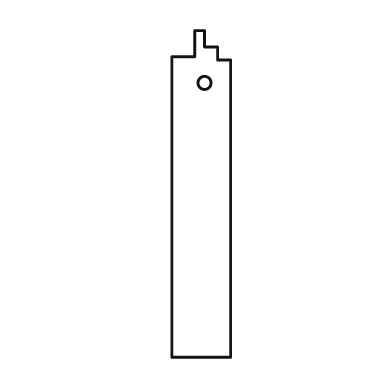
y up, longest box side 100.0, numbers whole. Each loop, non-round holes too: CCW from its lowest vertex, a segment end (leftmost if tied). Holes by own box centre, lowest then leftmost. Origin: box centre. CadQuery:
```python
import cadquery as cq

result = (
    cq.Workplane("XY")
    .moveTo(-9.0, -50.0)
    .lineTo(9.0, -50.0)
    .lineTo(9.0, 41.0)
    .lineTo(5.0, 41.0)
    .lineTo(5.0, 45.0)
    .lineTo(1.0, 45.0)
    .lineTo(1.0, 50.0)
    .lineTo(-2.0, 50.0)
    .lineTo(-2.0, 42.0)
    .lineTo(-9.0, 42.0)
    .close()
    .moveTo(1.0, 34.0)
    .circle(2.0)
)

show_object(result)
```